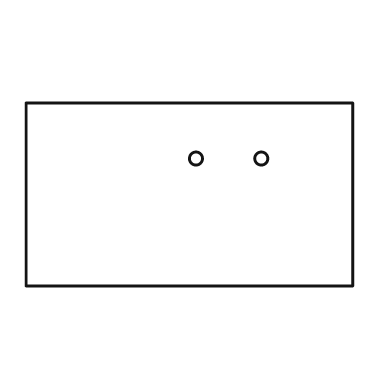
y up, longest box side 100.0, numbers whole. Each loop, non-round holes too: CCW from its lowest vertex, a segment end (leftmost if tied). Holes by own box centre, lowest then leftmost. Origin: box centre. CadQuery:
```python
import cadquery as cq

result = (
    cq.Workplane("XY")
    .moveTo(-50.0, -28.0)
    .lineTo(50.0, -28.0)
    .lineTo(50.0, 28.0)
    .lineTo(-50.0, 28.0)
    .close()
    .moveTo(2.0, 11.0)
    .circle(2.0)
    .moveTo(22.0, 11.0)
    .circle(2.0)
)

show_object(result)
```